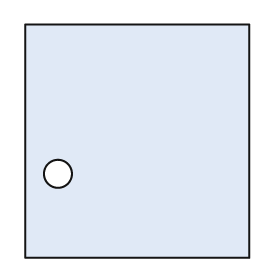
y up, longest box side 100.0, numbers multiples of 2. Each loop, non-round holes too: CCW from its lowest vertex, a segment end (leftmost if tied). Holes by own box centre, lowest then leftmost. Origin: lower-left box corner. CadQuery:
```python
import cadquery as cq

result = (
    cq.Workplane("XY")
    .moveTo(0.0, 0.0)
    .lineTo(96.0, 0.0)
    .lineTo(96.0, 100.0)
    .lineTo(0.0, 100.0)
    .close()
    .moveTo(14.0, 36.0)
    .circle(6.0)
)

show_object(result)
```